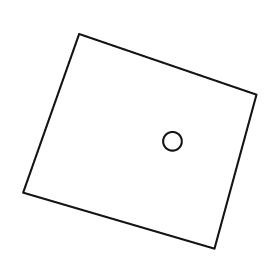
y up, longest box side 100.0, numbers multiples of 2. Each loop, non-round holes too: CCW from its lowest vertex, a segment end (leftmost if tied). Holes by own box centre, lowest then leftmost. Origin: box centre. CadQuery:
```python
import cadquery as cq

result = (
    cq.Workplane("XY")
    .moveTo(32.0, -46.0)
    .lineTo(50.0, 20.0)
    .lineTo(-26.0, 46.0)
    .lineTo(-50.0, -22.0)
    .close()
    .moveTo(14.0, 0.0)
    .circle(4.0)
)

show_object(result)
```